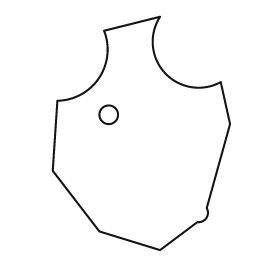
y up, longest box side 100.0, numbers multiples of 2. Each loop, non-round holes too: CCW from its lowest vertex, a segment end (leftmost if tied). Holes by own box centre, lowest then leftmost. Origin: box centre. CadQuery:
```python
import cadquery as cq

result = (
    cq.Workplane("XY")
    .moveTo(8.0, -50.0)
    .lineTo(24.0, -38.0)
    .threePointArc((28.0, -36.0), (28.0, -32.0))
    .lineTo(38.0, 4.0)
    .lineTo(34.0, 22.0)
    .threePointArc((10.0, 26.0), (8.0, 50.0))
    .lineTo(-16.0, 44.0)
    .threePointArc((-18.0, 24.0), (-36.0, 14.0))
    .lineTo(-38.0, -16.0)
    .lineTo(-18.0, -42.0)
    .close()
    .moveTo(-14.0, 8.0)
    .circle(4.0)
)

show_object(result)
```